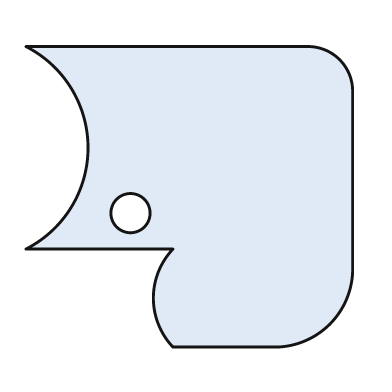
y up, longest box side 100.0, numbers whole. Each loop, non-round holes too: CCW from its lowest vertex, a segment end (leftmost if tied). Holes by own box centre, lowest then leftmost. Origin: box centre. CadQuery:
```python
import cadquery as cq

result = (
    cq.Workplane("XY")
    .moveTo(-5.0, -46.0)
    .lineTo(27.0, -46.0)
    .threePointArc((43.0, -39.0), (50.0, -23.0))
    .lineTo(50.0, 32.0)
    .threePointArc((46.0, 42.0), (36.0, 46.0))
    .lineTo(-50.0, 46.0)
    .threePointArc((-31.0, 15.0), (-50.0, -16.0))
    .lineTo(-5.0, -16.0)
    .threePointArc((-11.0, -31.0), (-5.0, -46.0))
    .close()
    .moveTo(-18.0, -5.0)
    .circle(6.0)
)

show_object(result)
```